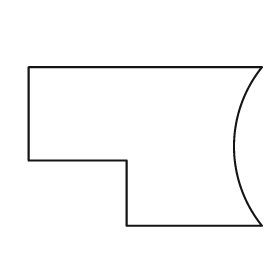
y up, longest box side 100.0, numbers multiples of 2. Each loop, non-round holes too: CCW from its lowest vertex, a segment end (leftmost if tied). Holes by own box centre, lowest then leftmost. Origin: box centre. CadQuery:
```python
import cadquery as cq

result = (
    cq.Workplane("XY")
    .moveTo(-8.0, -34.0)
    .lineTo(50.0, -34.0)
    .threePointArc((38.0, 0.0), (50.0, 34.0))
    .lineTo(-50.0, 34.0)
    .lineTo(-50.0, -6.0)
    .lineTo(-8.0, -6.0)
    .close()
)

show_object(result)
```